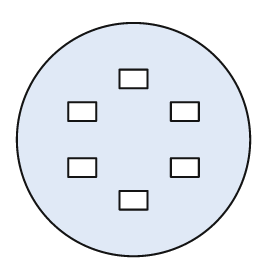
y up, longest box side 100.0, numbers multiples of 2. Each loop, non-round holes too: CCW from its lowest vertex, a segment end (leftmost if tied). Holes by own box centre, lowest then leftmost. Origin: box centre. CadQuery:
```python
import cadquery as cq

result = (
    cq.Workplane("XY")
    .moveTo(0.0, 0.0)
    .circle(50.0)
    .moveTo(-6.0, -30.0)
    .lineTo(6.0, -30.0)
    .lineTo(6.0, -22.0)
    .lineTo(-6.0, -22.0)
    .close()
    .moveTo(-28.0, -16.0)
    .lineTo(-16.0, -16.0)
    .lineTo(-16.0, -8.0)
    .lineTo(-28.0, -8.0)
    .close()
    .moveTo(16.0, -16.0)
    .lineTo(28.0, -16.0)
    .lineTo(28.0, -8.0)
    .lineTo(16.0, -8.0)
    .close()
    .moveTo(-28.0, 8.0)
    .lineTo(-16.0, 8.0)
    .lineTo(-16.0, 16.0)
    .lineTo(-28.0, 16.0)
    .close()
    .moveTo(16.0, 8.0)
    .lineTo(28.0, 8.0)
    .lineTo(28.0, 16.0)
    .lineTo(16.0, 16.0)
    .close()
    .moveTo(-6.0, 22.0)
    .lineTo(6.0, 22.0)
    .lineTo(6.0, 30.0)
    .lineTo(-6.0, 30.0)
    .close()
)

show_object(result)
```